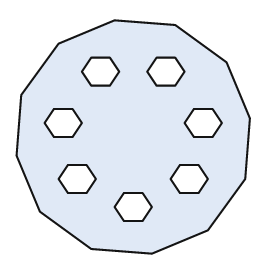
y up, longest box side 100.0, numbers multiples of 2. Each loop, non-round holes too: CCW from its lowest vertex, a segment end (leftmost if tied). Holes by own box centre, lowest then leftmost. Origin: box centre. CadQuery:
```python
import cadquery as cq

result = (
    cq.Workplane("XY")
    .moveTo(8.0, -50.0)
    .lineTo(32.0, -40.0)
    .lineTo(48.0, -18.0)
    .lineTo(50.0, 8.0)
    .lineTo(40.0, 32.0)
    .lineTo(18.0, 48.0)
    .lineTo(-8.0, 50.0)
    .lineTo(-32.0, 40.0)
    .lineTo(-48.0, 18.0)
    .lineTo(-50.0, -8.0)
    .lineTo(-40.0, -32.0)
    .lineTo(-18.0, -48.0)
    .close()
    .moveTo(-4.0, -36.0)
    .lineTo(4.0, -36.0)
    .lineTo(8.0, -30.0)
    .lineTo(4.0, -24.0)
    .lineTo(-4.0, -24.0)
    .lineTo(-8.0, -30.0)
    .close()
    .moveTo(-28.0, -24.0)
    .lineTo(-20.0, -24.0)
    .lineTo(-16.0, -18.0)
    .lineTo(-20.0, -12.0)
    .lineTo(-28.0, -12.0)
    .lineTo(-32.0, -18.0)
    .close()
    .moveTo(20.0, -24.0)
    .lineTo(28.0, -24.0)
    .lineTo(32.0, -18.0)
    .lineTo(28.0, -12.0)
    .lineTo(20.0, -12.0)
    .lineTo(16.0, -18.0)
    .close()
    .moveTo(-34.0, 0.0)
    .lineTo(-26.0, 0.0)
    .lineTo(-22.0, 6.0)
    .lineTo(-26.0, 12.0)
    .lineTo(-34.0, 12.0)
    .lineTo(-38.0, 6.0)
    .close()
    .moveTo(26.0, 0.0)
    .lineTo(34.0, 0.0)
    .lineTo(38.0, 6.0)
    .lineTo(34.0, 12.0)
    .lineTo(26.0, 12.0)
    .lineTo(22.0, 6.0)
    .close()
    .moveTo(-18.0, 22.0)
    .lineTo(-10.0, 22.0)
    .lineTo(-6.0, 28.0)
    .lineTo(-10.0, 34.0)
    .lineTo(-18.0, 34.0)
    .lineTo(-22.0, 28.0)
    .close()
    .moveTo(10.0, 22.0)
    .lineTo(18.0, 22.0)
    .lineTo(22.0, 28.0)
    .lineTo(18.0, 34.0)
    .lineTo(10.0, 34.0)
    .lineTo(6.0, 28.0)
    .close()
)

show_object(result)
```